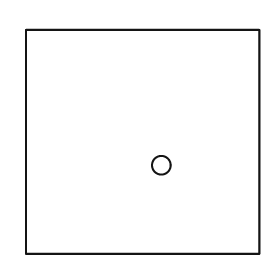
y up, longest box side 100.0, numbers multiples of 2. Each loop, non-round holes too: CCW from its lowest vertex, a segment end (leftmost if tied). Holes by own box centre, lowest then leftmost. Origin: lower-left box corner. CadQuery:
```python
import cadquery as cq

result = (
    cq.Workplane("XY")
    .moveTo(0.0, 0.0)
    .lineTo(100.0, 0.0)
    .lineTo(100.0, 96.0)
    .lineTo(0.0, 96.0)
    .close()
    .moveTo(58.0, 38.0)
    .circle(4.0)
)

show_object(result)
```